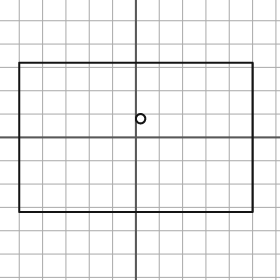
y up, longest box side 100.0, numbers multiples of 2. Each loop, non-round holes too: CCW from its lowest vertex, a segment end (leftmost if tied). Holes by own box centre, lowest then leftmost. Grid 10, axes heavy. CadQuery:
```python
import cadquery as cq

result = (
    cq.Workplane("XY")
    .moveTo(-50.0, -32.0)
    .lineTo(50.0, -32.0)
    .lineTo(50.0, 32.0)
    .lineTo(-50.0, 32.0)
    .close()
    .moveTo(2.0, 8.0)
    .circle(2.0)
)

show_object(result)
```